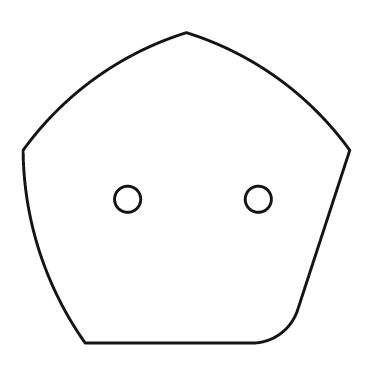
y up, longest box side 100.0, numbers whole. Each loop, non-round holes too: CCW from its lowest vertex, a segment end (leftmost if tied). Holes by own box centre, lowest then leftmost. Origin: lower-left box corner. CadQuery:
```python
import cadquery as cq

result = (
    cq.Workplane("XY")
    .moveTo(19.0, 0.0)
    .lineTo(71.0, 0.0)
    .threePointArc((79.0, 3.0), (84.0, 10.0))
    .lineTo(100.0, 59.0)
    .threePointArc((78.0, 81.0), (50.0, 95.0))
    .threePointArc((22.0, 81.0), (0.0, 59.0))
    .threePointArc((5.0, 28.0), (19.0, 0.0))
    .close()
    .moveTo(32.0, 44.0)
    .circle(4.0)
    .moveTo(72.0, 44.0)
    .circle(4.0)
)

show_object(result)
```